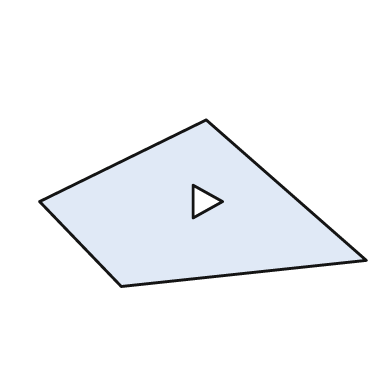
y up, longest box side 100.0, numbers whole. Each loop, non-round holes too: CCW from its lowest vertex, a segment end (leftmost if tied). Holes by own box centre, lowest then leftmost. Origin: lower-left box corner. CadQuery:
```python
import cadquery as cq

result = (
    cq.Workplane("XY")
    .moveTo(25.0, 0.0)
    .lineTo(100.0, 8.0)
    .lineTo(51.0, 51.0)
    .lineTo(0.0, 26.0)
    .close()
    .moveTo(47.0, 21.0)
    .lineTo(56.0, 26.0)
    .lineTo(47.0, 31.0)
    .close()
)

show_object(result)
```